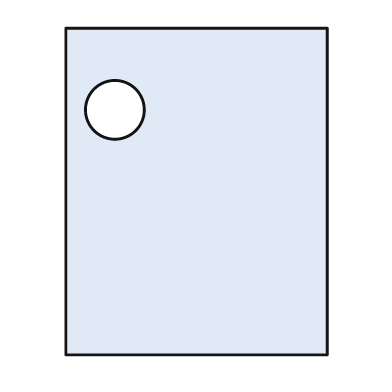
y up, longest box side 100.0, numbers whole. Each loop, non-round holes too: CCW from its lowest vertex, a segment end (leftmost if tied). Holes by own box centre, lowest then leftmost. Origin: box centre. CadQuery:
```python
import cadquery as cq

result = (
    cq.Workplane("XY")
    .moveTo(-40.0, -50.0)
    .lineTo(40.0, -50.0)
    .lineTo(40.0, 50.0)
    .lineTo(-40.0, 50.0)
    .close()
    .moveTo(-25.0, 25.0)
    .circle(9.0)
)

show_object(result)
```